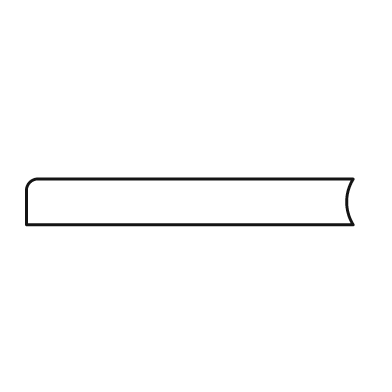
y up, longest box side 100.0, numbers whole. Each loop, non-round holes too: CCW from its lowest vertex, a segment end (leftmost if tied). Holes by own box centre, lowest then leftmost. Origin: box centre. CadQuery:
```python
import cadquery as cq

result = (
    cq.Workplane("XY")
    .moveTo(-50.0, -7.0)
    .lineTo(50.0, -7.0)
    .threePointArc((48.0, 0.0), (50.0, 7.0))
    .lineTo(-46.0, 7.0)
    .threePointArc((-49.0, 6.0), (-50.0, 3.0))
    .close()
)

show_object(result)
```